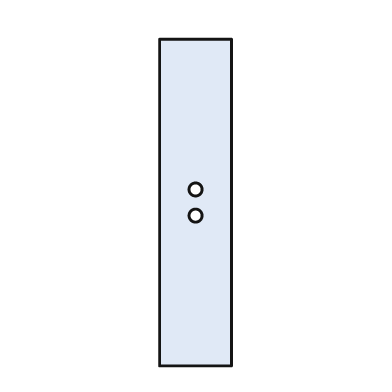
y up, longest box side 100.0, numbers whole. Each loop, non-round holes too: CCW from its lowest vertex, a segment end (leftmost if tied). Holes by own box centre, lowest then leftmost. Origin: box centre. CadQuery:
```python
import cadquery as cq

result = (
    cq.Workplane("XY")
    .moveTo(-11.0, -50.0)
    .lineTo(11.0, -50.0)
    .lineTo(11.0, 50.0)
    .lineTo(-11.0, 50.0)
    .close()
    .moveTo(0.0, -4.0)
    .circle(2.0)
    .moveTo(0.0, 4.0)
    .circle(2.0)
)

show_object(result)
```